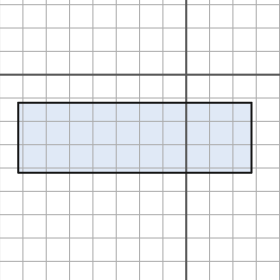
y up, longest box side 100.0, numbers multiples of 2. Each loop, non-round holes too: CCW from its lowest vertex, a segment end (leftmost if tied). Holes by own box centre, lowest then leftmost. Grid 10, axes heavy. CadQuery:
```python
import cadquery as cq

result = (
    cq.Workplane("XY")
    .moveTo(-72.0, -42.0)
    .lineTo(28.0, -42.0)
    .lineTo(28.0, -12.0)
    .lineTo(-72.0, -12.0)
    .close()
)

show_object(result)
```